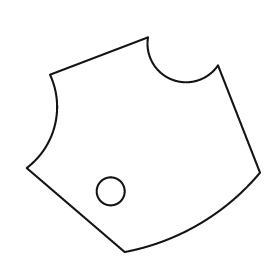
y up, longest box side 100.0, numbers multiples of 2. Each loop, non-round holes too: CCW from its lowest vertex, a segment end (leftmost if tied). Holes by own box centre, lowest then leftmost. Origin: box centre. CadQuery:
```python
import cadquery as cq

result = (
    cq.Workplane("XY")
    .moveTo(-8.0, -46.0)
    .threePointArc((24.0, -34.0), (50.0, -12.0))
    .lineTo(32.0, 34.0)
    .threePointArc((12.0, 28.0), (2.0, 46.0))
    .lineTo(-40.0, 30.0)
    .threePointArc((-38.0, 8.0), (-50.0, -10.0))
    .close()
    .moveTo(-14.0, -20.0)
    .circle(6.0)
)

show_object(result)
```